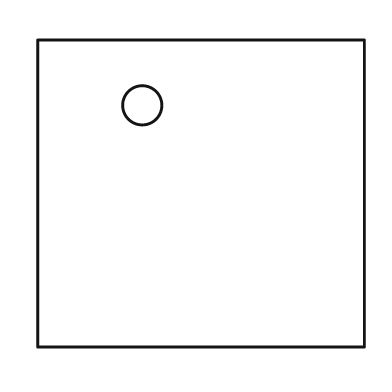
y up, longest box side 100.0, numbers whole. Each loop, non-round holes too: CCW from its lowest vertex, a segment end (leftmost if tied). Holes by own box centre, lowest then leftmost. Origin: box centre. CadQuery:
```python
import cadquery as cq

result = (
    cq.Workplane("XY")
    .moveTo(-50.0, -47.0)
    .lineTo(50.0, -47.0)
    .lineTo(50.0, 47.0)
    .lineTo(-50.0, 47.0)
    .close()
    .moveTo(-18.0, 27.0)
    .circle(6.0)
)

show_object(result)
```